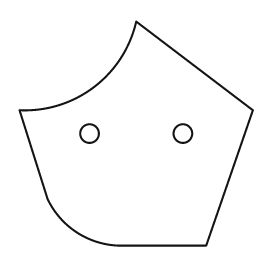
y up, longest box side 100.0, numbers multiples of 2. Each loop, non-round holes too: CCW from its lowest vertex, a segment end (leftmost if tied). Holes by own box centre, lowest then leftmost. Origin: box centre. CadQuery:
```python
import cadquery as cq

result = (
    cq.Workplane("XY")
    .moveTo(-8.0, -48.0)
    .lineTo(30.0, -48.0)
    .lineTo(50.0, 10.0)
    .lineTo(0.0, 48.0)
    .threePointArc((-18.0, 20.0), (-50.0, 10.0))
    .lineTo(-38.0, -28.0)
    .threePointArc((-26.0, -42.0), (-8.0, -48.0))
    .close()
    .moveTo(-20.0, 0.0)
    .circle(4.0)
    .moveTo(20.0, 0.0)
    .circle(4.0)
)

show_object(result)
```